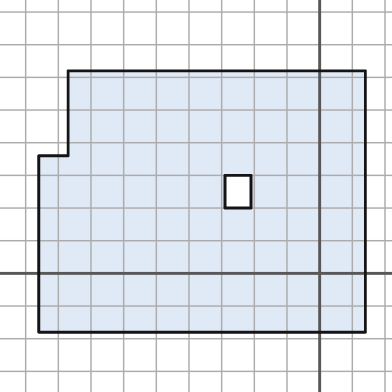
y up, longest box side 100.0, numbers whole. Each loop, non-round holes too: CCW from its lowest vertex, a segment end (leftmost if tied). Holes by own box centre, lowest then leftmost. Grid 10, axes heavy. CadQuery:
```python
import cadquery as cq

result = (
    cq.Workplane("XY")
    .moveTo(-86.0, -18.0)
    .lineTo(14.0, -18.0)
    .lineTo(14.0, 62.0)
    .lineTo(-77.0, 62.0)
    .lineTo(-77.0, 36.0)
    .lineTo(-86.0, 36.0)
    .close()
    .moveTo(-29.0, 20.0)
    .lineTo(-21.0, 20.0)
    .lineTo(-21.0, 30.0)
    .lineTo(-29.0, 30.0)
    .close()
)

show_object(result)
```